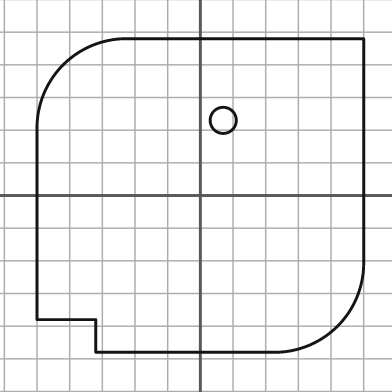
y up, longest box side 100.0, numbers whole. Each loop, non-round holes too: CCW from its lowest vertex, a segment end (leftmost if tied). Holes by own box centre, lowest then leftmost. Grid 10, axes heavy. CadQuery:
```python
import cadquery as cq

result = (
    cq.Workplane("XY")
    .moveTo(-32.0, -48.0)
    .lineTo(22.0, -48.0)
    .threePointArc((42.0, -40.0), (50.0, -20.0))
    .lineTo(50.0, 48.0)
    .lineTo(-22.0, 48.0)
    .threePointArc((-42.0, 40.0), (-50.0, 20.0))
    .lineTo(-50.0, -38.0)
    .lineTo(-32.0, -38.0)
    .close()
    .moveTo(7.0, 23.0)
    .circle(4.0)
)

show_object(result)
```